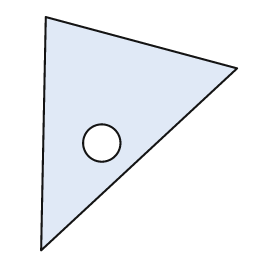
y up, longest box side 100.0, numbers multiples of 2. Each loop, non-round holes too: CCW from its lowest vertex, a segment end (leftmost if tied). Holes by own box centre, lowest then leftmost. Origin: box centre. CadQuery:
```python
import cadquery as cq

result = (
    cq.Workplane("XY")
    .moveTo(-42.0, -50.0)
    .lineTo(42.0, 28.0)
    .lineTo(-40.0, 50.0)
    .close()
    .moveTo(-16.0, -4.0)
    .circle(8.0)
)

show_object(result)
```